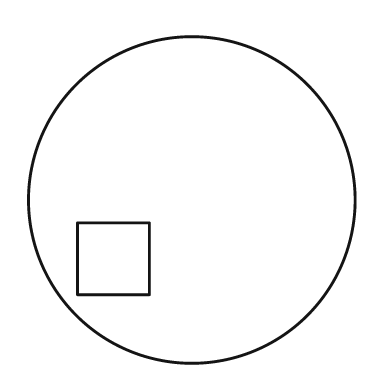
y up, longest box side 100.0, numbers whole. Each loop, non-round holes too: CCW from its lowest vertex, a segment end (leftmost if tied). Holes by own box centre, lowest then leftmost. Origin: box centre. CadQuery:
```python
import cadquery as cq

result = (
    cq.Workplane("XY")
    .moveTo(0.0, 0.0)
    .circle(50.0)
    .moveTo(-35.0, -29.0)
    .lineTo(-13.0, -29.0)
    .lineTo(-13.0, -7.0)
    .lineTo(-35.0, -7.0)
    .close()
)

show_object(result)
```